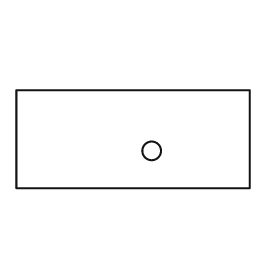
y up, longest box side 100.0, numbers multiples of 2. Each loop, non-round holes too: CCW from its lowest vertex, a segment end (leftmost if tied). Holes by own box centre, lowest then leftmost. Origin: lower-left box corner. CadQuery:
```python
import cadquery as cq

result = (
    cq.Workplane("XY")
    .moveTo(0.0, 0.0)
    .lineTo(100.0, 0.0)
    .lineTo(100.0, 42.0)
    .lineTo(0.0, 42.0)
    .close()
    .moveTo(58.0, 16.0)
    .circle(4.0)
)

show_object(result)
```